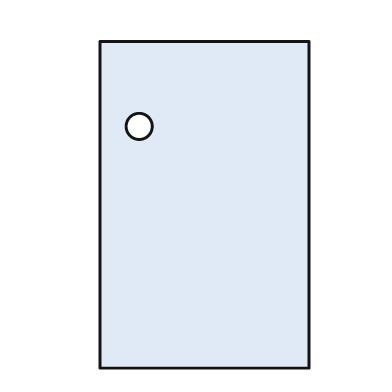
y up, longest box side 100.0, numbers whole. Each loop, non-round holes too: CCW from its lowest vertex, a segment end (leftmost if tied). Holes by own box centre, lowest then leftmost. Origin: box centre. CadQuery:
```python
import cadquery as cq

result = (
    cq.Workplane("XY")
    .moveTo(-32.0, -50.0)
    .lineTo(32.0, -50.0)
    .lineTo(32.0, 50.0)
    .lineTo(-32.0, 50.0)
    .close()
    .moveTo(-20.0, 24.0)
    .circle(4.0)
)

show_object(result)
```